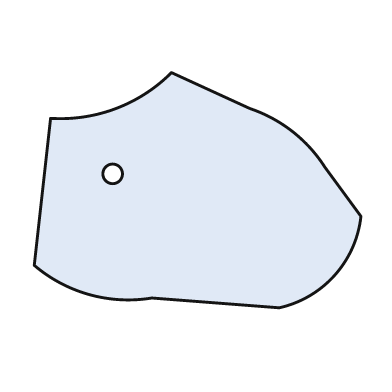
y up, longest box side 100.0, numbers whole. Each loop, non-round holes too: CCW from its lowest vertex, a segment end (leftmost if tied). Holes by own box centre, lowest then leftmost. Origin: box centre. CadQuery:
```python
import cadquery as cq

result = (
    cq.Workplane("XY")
    .moveTo(25.0, -36.0)
    .threePointArc((42.0, -26.0), (50.0, -8.0))
    .lineTo(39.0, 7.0)
    .threePointArc((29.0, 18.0), (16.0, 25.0))
    .lineTo(-8.0, 36.0)
    .threePointArc((-25.0, 25.0), (-45.0, 22.0))
    .lineTo(-50.0, -23.0)
    .threePointArc((-33.0, -32.0), (-14.0, -33.0))
    .close()
    .moveTo(-26.0, 5.0)
    .circle(3.0)
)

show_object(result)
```